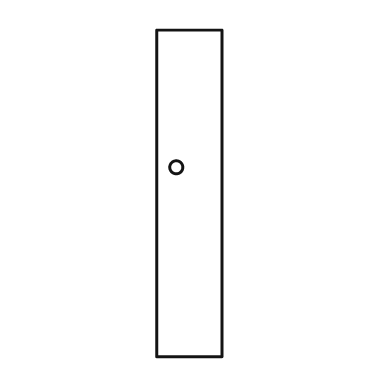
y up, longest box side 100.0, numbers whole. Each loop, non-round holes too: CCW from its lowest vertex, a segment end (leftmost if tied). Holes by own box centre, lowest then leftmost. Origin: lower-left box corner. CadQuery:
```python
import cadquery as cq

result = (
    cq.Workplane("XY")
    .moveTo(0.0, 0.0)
    .lineTo(20.0, 0.0)
    .lineTo(20.0, 100.0)
    .lineTo(0.0, 100.0)
    .close()
    .moveTo(6.0, 58.0)
    .circle(2.0)
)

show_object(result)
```